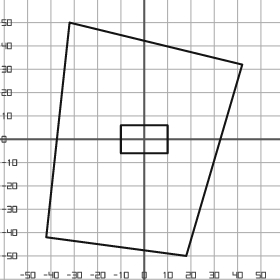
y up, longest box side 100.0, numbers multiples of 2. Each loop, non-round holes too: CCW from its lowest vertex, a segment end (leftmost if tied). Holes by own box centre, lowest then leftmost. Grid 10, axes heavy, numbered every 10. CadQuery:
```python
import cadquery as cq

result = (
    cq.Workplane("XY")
    .moveTo(18.0, -50.0)
    .lineTo(42.0, 32.0)
    .lineTo(-32.0, 50.0)
    .lineTo(-42.0, -42.0)
    .close()
    .moveTo(-10.0, -6.0)
    .lineTo(10.0, -6.0)
    .lineTo(10.0, 6.0)
    .lineTo(-10.0, 6.0)
    .close()
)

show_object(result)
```